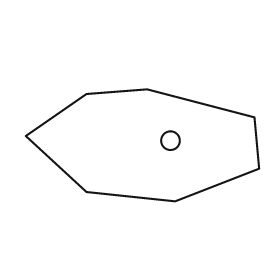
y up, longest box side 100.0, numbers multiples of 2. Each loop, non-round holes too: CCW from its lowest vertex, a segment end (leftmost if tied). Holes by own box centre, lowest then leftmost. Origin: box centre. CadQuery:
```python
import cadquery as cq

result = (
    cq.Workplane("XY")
    .moveTo(14.0, -24.0)
    .lineTo(50.0, -10.0)
    .lineTo(48.0, 12.0)
    .lineTo(2.0, 24.0)
    .lineTo(-24.0, 22.0)
    .lineTo(-50.0, 4.0)
    .lineTo(-24.0, -20.0)
    .close()
    .moveTo(12.0, 2.0)
    .circle(4.0)
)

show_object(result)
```